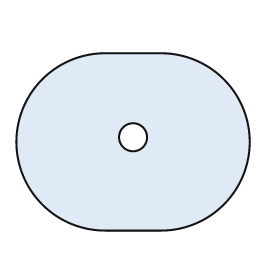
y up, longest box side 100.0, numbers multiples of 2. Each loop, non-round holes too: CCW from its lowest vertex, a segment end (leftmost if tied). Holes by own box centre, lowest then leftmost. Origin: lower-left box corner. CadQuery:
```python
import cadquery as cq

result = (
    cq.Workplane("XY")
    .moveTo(38.0, 0.0)
    .lineTo(62.0, 0.0)
    .threePointArc((100.0, 38.0), (62.0, 76.0))
    .lineTo(38.0, 76.0)
    .threePointArc((0.0, 38.0), (38.0, 0.0))
    .close()
    .moveTo(50.0, 40.0)
    .circle(6.0)
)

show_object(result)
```